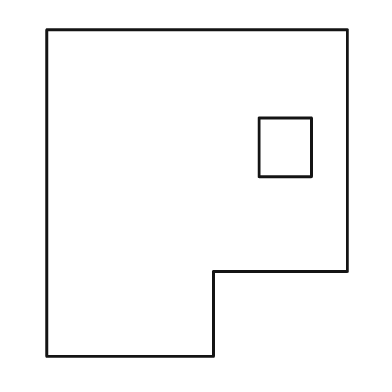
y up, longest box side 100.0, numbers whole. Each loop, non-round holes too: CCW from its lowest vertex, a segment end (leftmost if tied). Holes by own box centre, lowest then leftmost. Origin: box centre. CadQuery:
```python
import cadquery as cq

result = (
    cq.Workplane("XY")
    .moveTo(-46.0, -50.0)
    .lineTo(5.0, -50.0)
    .lineTo(5.0, -24.0)
    .lineTo(46.0, -24.0)
    .lineTo(46.0, 50.0)
    .lineTo(-46.0, 50.0)
    .close()
    .moveTo(19.0, 5.0)
    .lineTo(35.0, 5.0)
    .lineTo(35.0, 23.0)
    .lineTo(19.0, 23.0)
    .close()
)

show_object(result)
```